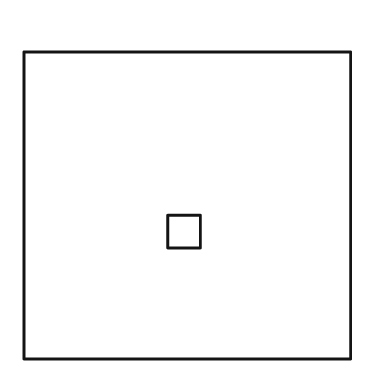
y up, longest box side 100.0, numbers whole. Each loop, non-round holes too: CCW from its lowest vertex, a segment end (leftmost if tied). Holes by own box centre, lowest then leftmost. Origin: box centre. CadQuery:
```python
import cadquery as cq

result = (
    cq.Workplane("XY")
    .moveTo(-50.0, -47.0)
    .lineTo(50.0, -47.0)
    .lineTo(50.0, 47.0)
    .lineTo(-50.0, 47.0)
    .close()
    .moveTo(-6.0, -13.0)
    .lineTo(4.0, -13.0)
    .lineTo(4.0, -3.0)
    .lineTo(-6.0, -3.0)
    .close()
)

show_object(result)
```